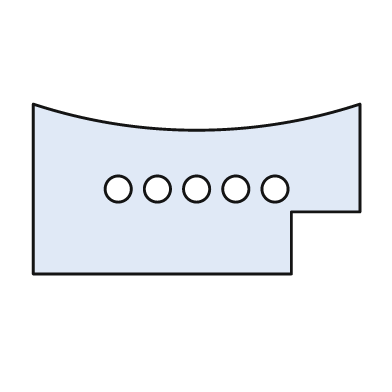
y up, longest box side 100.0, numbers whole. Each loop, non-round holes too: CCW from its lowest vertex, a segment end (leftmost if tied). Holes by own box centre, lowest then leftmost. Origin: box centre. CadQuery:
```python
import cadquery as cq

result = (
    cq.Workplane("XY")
    .moveTo(-50.0, -26.0)
    .lineTo(29.0, -26.0)
    .lineTo(29.0, -7.0)
    .lineTo(50.0, -7.0)
    .lineTo(50.0, 26.0)
    .threePointArc((0.0, 18.0), (-50.0, 26.0))
    .close()
    .moveTo(-24.0, 0.0)
    .circle(4.0)
    .moveTo(-12.0, 0.0)
    .circle(4.0)
    .moveTo(0.0, 0.0)
    .circle(4.0)
    .moveTo(12.0, 0.0)
    .circle(4.0)
    .moveTo(24.0, 0.0)
    .circle(4.0)
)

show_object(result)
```